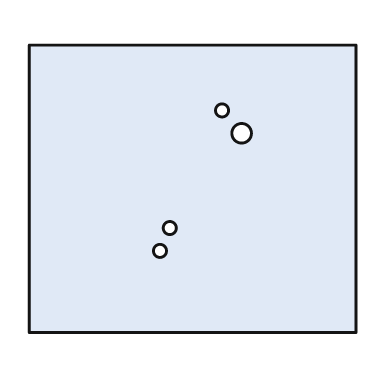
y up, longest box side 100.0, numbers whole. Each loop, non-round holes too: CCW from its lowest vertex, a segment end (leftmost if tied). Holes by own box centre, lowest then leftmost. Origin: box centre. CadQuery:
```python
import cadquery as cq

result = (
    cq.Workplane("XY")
    .moveTo(-50.0, -44.0)
    .lineTo(50.0, -44.0)
    .lineTo(50.0, 44.0)
    .lineTo(-50.0, 44.0)
    .close()
    .moveTo(-10.0, -19.0)
    .circle(2.0)
    .moveTo(-7.0, -12.0)
    .circle(2.0)
    .moveTo(15.0, 17.0)
    .circle(3.0)
    .moveTo(9.0, 24.0)
    .circle(2.0)
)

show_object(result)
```